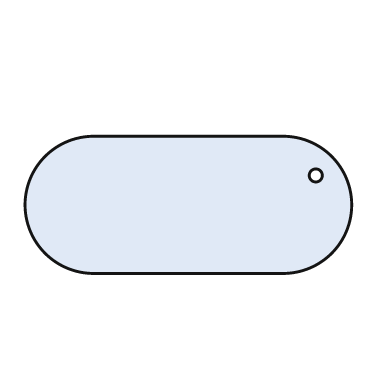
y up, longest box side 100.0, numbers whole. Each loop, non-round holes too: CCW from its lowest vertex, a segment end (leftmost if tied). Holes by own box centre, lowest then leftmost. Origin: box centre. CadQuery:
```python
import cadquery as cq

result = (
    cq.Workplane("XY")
    .moveTo(-29.0, -21.0)
    .lineTo(29.0, -21.0)
    .threePointArc((50.0, 0.0), (29.0, 21.0))
    .lineTo(-29.0, 21.0)
    .threePointArc((-50.0, 0.0), (-29.0, -21.0))
    .close()
    .moveTo(39.0, 9.0)
    .circle(2.0)
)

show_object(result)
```